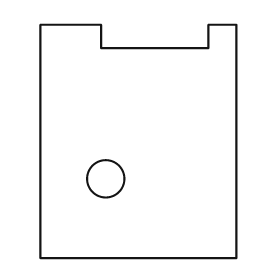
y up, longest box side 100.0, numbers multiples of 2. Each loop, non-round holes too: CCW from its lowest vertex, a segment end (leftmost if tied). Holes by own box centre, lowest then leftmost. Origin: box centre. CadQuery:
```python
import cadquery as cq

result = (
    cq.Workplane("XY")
    .moveTo(-42.0, -50.0)
    .lineTo(42.0, -50.0)
    .lineTo(42.0, 50.0)
    .lineTo(30.0, 50.0)
    .lineTo(30.0, 40.0)
    .lineTo(-16.0, 40.0)
    .lineTo(-16.0, 50.0)
    .lineTo(-42.0, 50.0)
    .close()
    .moveTo(-14.0, -16.0)
    .circle(8.0)
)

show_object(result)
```